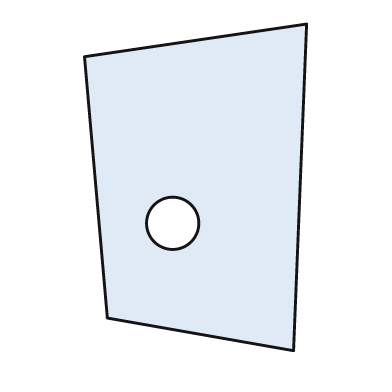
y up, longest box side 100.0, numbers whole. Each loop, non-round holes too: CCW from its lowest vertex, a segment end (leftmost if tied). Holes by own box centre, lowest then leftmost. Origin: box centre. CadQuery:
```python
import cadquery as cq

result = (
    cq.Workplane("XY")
    .moveTo(30.0, -50.0)
    .lineTo(34.0, 50.0)
    .lineTo(-34.0, 40.0)
    .lineTo(-27.0, -40.0)
    .close()
    .moveTo(-7.0, -11.0)
    .circle(8.0)
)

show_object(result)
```